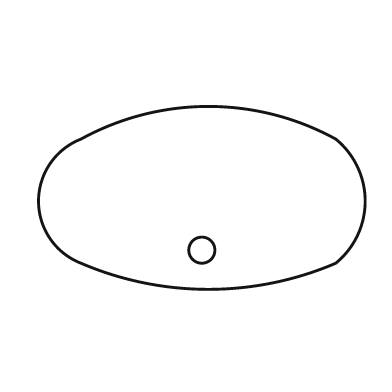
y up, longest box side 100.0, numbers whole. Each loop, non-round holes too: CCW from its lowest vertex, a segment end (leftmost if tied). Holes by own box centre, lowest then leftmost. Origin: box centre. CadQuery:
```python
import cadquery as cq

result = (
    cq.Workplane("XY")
    .moveTo(-37.0, -20.0)
    .threePointArc((2.0, -28.0), (41.0, -20.0))
    .threePointArc((50.0, -1.0), (41.0, 18.0))
    .threePointArc((2.0, 28.0), (-37.0, 18.0))
    .threePointArc((-50.0, -1.0), (-37.0, -20.0))
    .close()
    .moveTo(0.0, -16.0)
    .circle(4.0)
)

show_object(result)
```